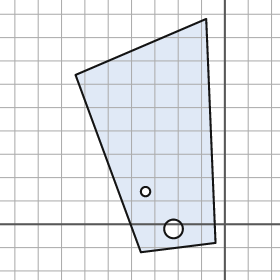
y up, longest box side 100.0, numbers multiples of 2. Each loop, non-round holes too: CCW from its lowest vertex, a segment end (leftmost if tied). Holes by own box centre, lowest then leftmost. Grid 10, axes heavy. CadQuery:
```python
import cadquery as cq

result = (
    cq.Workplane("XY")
    .moveTo(-36.0, -12.0)
    .lineTo(-4.0, -8.0)
    .lineTo(-8.0, 88.0)
    .lineTo(-64.0, 64.0)
    .close()
    .moveTo(-22.0, -2.0)
    .circle(4.0)
    .moveTo(-34.0, 14.0)
    .circle(2.0)
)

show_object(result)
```